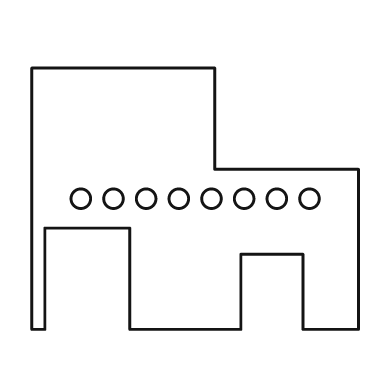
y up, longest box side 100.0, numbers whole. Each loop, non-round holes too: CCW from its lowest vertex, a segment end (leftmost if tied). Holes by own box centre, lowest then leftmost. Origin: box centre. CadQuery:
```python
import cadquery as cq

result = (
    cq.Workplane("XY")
    .moveTo(-50.0, -40.0)
    .lineTo(-46.0, -40.0)
    .lineTo(-46.0, -9.0)
    .lineTo(-20.0, -9.0)
    .lineTo(-20.0, -40.0)
    .lineTo(14.0, -40.0)
    .lineTo(14.0, -17.0)
    .lineTo(33.0, -17.0)
    .lineTo(33.0, -40.0)
    .lineTo(50.0, -40.0)
    .lineTo(50.0, 9.0)
    .lineTo(6.0, 9.0)
    .lineTo(6.0, 40.0)
    .lineTo(-50.0, 40.0)
    .close()
    .moveTo(-35.0, 0.0)
    .circle(3.0)
    .moveTo(-25.0, 0.0)
    .circle(3.0)
    .moveTo(-15.0, 0.0)
    .circle(3.0)
    .moveTo(-5.0, 0.0)
    .circle(3.0)
    .moveTo(5.0, 0.0)
    .circle(3.0)
    .moveTo(15.0, 0.0)
    .circle(3.0)
    .moveTo(25.0, 0.0)
    .circle(3.0)
    .moveTo(35.0, 0.0)
    .circle(3.0)
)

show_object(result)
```